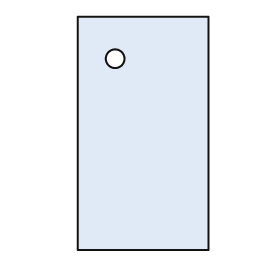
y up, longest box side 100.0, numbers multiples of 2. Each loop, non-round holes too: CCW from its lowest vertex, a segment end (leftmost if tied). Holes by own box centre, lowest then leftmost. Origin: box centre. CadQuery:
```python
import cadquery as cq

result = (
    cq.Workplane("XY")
    .moveTo(-28.0, -50.0)
    .lineTo(28.0, -50.0)
    .lineTo(28.0, 50.0)
    .lineTo(-28.0, 50.0)
    .close()
    .moveTo(-12.0, 32.0)
    .circle(4.0)
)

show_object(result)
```